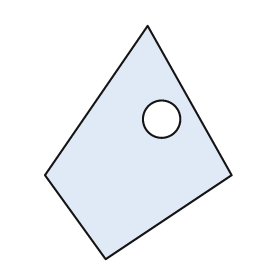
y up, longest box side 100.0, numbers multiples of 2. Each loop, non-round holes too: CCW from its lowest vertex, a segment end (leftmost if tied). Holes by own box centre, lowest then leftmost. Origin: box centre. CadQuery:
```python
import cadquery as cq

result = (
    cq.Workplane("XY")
    .moveTo(-14.0, -50.0)
    .lineTo(40.0, -14.0)
    .lineTo(4.0, 50.0)
    .lineTo(-40.0, -14.0)
    .close()
    .moveTo(10.0, 10.0)
    .circle(8.0)
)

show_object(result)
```